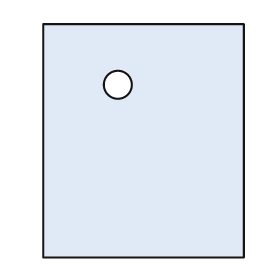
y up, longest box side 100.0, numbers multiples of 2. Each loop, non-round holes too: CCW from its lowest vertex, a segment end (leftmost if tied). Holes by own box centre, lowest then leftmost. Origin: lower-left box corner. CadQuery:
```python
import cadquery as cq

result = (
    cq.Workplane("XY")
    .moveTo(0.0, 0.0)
    .lineTo(86.0, 0.0)
    .lineTo(86.0, 100.0)
    .lineTo(0.0, 100.0)
    .close()
    .moveTo(32.0, 74.0)
    .circle(6.0)
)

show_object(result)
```